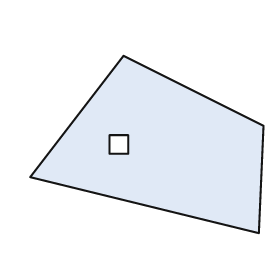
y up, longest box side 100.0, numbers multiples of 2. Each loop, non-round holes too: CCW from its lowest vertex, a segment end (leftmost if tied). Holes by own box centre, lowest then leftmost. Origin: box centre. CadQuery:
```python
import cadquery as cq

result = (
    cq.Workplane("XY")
    .moveTo(48.0, -38.0)
    .lineTo(50.0, 8.0)
    .lineTo(-10.0, 38.0)
    .lineTo(-50.0, -14.0)
    .close()
    .moveTo(-16.0, -4.0)
    .lineTo(-8.0, -4.0)
    .lineTo(-8.0, 4.0)
    .lineTo(-16.0, 4.0)
    .close()
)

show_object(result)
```